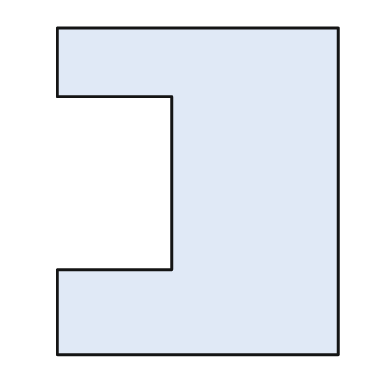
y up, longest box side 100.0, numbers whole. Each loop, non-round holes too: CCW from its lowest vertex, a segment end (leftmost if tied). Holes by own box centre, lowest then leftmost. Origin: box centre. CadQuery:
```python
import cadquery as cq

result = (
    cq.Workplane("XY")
    .moveTo(-43.0, -50.0)
    .lineTo(43.0, -50.0)
    .lineTo(43.0, 50.0)
    .lineTo(-43.0, 50.0)
    .lineTo(-43.0, 29.0)
    .lineTo(-8.0, 29.0)
    .lineTo(-8.0, -24.0)
    .lineTo(-43.0, -24.0)
    .close()
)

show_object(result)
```